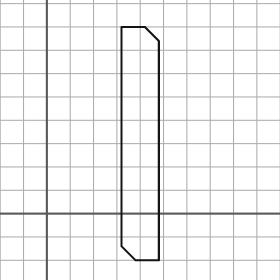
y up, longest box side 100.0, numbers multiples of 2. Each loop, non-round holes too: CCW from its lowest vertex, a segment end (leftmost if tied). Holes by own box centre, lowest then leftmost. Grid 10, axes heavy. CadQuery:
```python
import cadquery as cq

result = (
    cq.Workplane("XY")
    .moveTo(38.0, -20.0)
    .lineTo(48.0, -20.0)
    .lineTo(48.0, 74.0)
    .lineTo(42.0, 80.0)
    .lineTo(32.0, 80.0)
    .lineTo(32.0, -14.0)
    .close()
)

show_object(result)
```